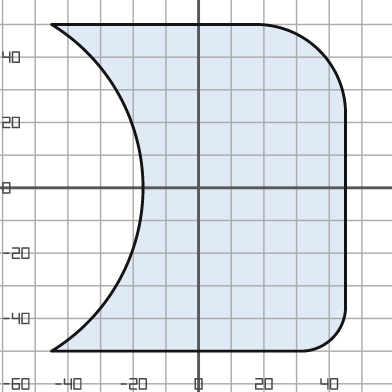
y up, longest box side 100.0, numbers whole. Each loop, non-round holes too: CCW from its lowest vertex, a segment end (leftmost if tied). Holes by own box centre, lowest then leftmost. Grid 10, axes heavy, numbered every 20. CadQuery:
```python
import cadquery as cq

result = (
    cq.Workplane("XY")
    .moveTo(-45.0, -50.0)
    .lineTo(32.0, -50.0)
    .threePointArc((41.0, -46.0), (45.0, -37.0))
    .lineTo(45.0, 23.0)
    .threePointArc((37.0, 42.0), (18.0, 50.0))
    .lineTo(-45.0, 50.0)
    .threePointArc((-17.0, 0.0), (-45.0, -50.0))
    .close()
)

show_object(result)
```